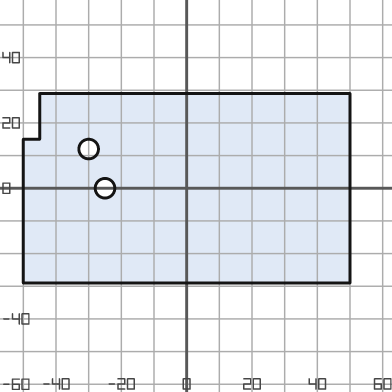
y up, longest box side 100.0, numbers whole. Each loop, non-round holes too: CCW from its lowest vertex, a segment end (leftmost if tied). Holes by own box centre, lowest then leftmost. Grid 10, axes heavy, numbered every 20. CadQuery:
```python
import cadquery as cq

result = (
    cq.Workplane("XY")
    .moveTo(-50.0, -29.0)
    .lineTo(50.0, -29.0)
    .lineTo(50.0, 29.0)
    .lineTo(-45.0, 29.0)
    .lineTo(-45.0, 15.0)
    .lineTo(-50.0, 15.0)
    .close()
    .moveTo(-25.0, 0.0)
    .circle(3.0)
    .moveTo(-30.0, 12.0)
    .circle(3.0)
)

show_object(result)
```